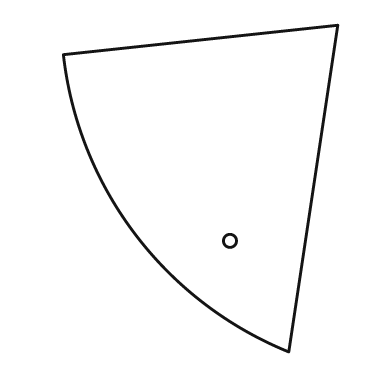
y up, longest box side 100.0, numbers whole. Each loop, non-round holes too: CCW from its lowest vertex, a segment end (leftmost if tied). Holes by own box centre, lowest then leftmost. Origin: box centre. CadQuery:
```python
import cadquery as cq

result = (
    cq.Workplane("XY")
    .moveTo(27.0, -50.0)
    .lineTo(42.0, 50.0)
    .lineTo(-42.0, 41.0)
    .threePointArc((-20.0, -14.0), (27.0, -50.0))
    .close()
    .moveTo(9.0, -16.0)
    .circle(2.0)
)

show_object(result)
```